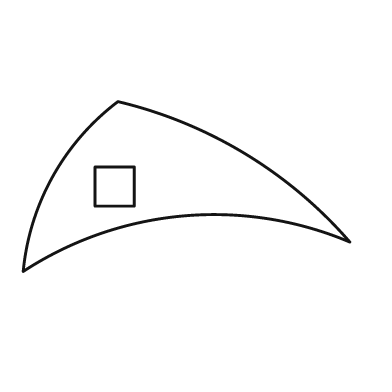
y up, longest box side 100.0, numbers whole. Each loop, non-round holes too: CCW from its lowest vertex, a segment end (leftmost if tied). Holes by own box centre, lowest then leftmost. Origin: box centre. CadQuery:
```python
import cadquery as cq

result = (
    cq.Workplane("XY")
    .moveTo(-50.0, -26.0)
    .threePointArc((-1.0, -9.0), (50.0, -17.0))
    .threePointArc((18.0, 10.0), (-21.0, 26.0))
    .threePointArc((-41.0, 3.0), (-50.0, -26.0))
    .close()
    .moveTo(-28.0, -6.0)
    .lineTo(-16.0, -6.0)
    .lineTo(-16.0, 6.0)
    .lineTo(-28.0, 6.0)
    .close()
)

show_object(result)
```